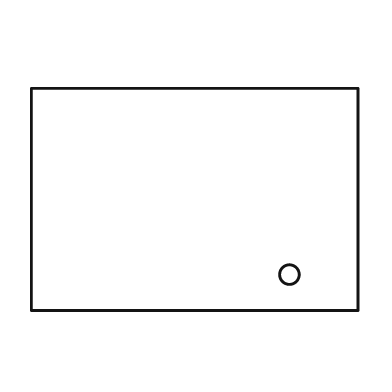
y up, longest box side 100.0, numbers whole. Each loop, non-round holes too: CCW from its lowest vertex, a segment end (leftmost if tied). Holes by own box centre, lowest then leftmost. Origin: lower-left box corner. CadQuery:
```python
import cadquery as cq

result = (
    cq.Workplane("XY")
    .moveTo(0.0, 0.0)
    .lineTo(100.0, 0.0)
    .lineTo(100.0, 68.0)
    .lineTo(0.0, 68.0)
    .close()
    .moveTo(79.0, 11.0)
    .circle(3.0)
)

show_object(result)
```